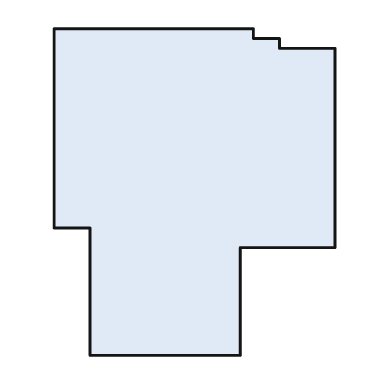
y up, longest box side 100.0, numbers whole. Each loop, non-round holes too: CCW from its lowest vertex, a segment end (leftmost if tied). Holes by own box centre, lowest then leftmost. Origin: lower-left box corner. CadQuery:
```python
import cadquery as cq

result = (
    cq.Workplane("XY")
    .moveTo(11.0, 0.0)
    .lineTo(57.0, 0.0)
    .lineTo(57.0, 33.0)
    .lineTo(86.0, 33.0)
    .lineTo(86.0, 94.0)
    .lineTo(69.0, 94.0)
    .lineTo(69.0, 97.0)
    .lineTo(61.0, 97.0)
    .lineTo(61.0, 100.0)
    .lineTo(0.0, 100.0)
    .lineTo(0.0, 39.0)
    .lineTo(11.0, 39.0)
    .close()
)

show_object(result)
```